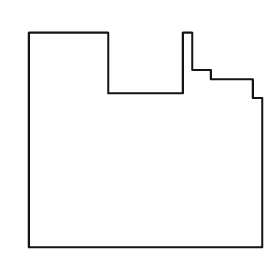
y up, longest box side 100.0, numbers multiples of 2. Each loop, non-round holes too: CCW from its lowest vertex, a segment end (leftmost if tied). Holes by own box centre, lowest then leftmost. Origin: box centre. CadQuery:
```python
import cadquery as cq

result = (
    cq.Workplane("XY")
    .moveTo(-50.0, -46.0)
    .lineTo(50.0, -46.0)
    .lineTo(50.0, 18.0)
    .lineTo(46.0, 18.0)
    .lineTo(46.0, 26.0)
    .lineTo(28.0, 26.0)
    .lineTo(28.0, 30.0)
    .lineTo(20.0, 30.0)
    .lineTo(20.0, 46.0)
    .lineTo(16.0, 46.0)
    .lineTo(16.0, 20.0)
    .lineTo(-16.0, 20.0)
    .lineTo(-16.0, 46.0)
    .lineTo(-50.0, 46.0)
    .close()
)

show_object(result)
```